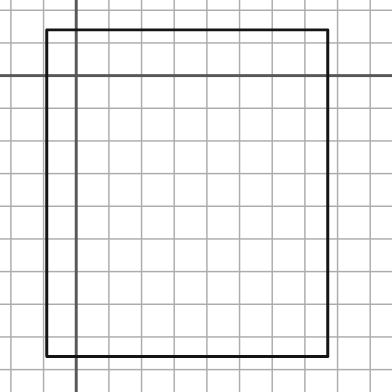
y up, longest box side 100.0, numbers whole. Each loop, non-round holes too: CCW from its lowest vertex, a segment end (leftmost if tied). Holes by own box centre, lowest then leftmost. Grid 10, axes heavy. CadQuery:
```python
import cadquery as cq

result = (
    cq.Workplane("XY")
    .moveTo(-9.0, -86.0)
    .lineTo(77.0, -86.0)
    .lineTo(77.0, 14.0)
    .lineTo(-9.0, 14.0)
    .close()
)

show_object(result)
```